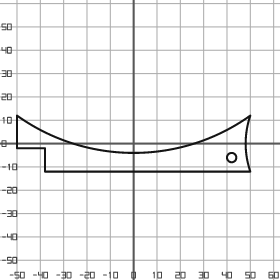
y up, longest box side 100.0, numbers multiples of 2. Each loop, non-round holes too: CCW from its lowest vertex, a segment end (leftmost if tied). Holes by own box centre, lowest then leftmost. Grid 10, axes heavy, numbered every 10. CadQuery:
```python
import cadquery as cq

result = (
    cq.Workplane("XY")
    .moveTo(-38.0, -12.0)
    .lineTo(50.0, -12.0)
    .threePointArc((48.0, 0.0), (50.0, 12.0))
    .threePointArc((0.0, -4.0), (-50.0, 12.0))
    .lineTo(-50.0, -2.0)
    .lineTo(-38.0, -2.0)
    .close()
    .moveTo(42.0, -6.0)
    .circle(2.0)
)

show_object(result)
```